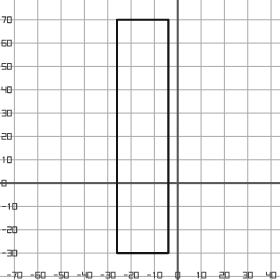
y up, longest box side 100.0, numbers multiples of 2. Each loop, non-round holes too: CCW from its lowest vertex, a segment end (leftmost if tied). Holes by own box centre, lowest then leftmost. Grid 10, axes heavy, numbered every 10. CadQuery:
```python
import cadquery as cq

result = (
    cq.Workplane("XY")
    .moveTo(-26.0, -30.0)
    .lineTo(-4.0, -30.0)
    .lineTo(-4.0, 70.0)
    .lineTo(-26.0, 70.0)
    .close()
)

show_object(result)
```